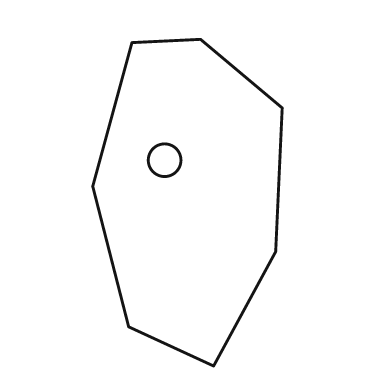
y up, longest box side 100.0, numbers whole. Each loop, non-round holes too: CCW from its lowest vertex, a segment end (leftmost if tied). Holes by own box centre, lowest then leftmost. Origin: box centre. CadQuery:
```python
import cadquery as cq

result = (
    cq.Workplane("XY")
    .moveTo(8.0, -50.0)
    .lineTo(27.0, -15.0)
    .lineTo(29.0, 29.0)
    .lineTo(4.0, 50.0)
    .lineTo(-17.0, 49.0)
    .lineTo(-29.0, 5.0)
    .lineTo(-18.0, -38.0)
    .close()
    .moveTo(-7.0, 13.0)
    .circle(5.0)
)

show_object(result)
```